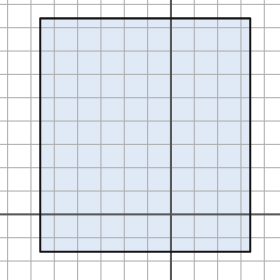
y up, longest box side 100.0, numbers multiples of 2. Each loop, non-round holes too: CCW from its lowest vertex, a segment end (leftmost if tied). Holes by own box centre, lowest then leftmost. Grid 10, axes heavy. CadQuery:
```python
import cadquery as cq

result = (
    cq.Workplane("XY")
    .moveTo(-56.0, -16.0)
    .lineTo(34.0, -16.0)
    .lineTo(34.0, 84.0)
    .lineTo(-56.0, 84.0)
    .close()
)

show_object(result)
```